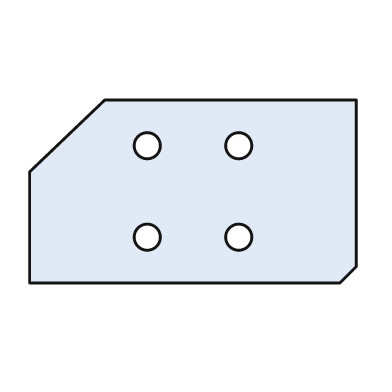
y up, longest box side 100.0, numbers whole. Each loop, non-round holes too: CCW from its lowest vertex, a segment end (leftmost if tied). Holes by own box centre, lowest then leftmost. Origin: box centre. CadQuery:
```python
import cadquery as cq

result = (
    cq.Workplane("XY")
    .moveTo(-50.0, -28.0)
    .lineTo(45.0, -28.0)
    .lineTo(50.0, -23.0)
    .lineTo(50.0, 28.0)
    .lineTo(-27.0, 28.0)
    .lineTo(-50.0, 6.0)
    .close()
    .moveTo(-14.0, -14.0)
    .circle(4.0)
    .moveTo(14.0, -14.0)
    .circle(4.0)
    .moveTo(-14.0, 14.0)
    .circle(4.0)
    .moveTo(14.0, 14.0)
    .circle(4.0)
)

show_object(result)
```